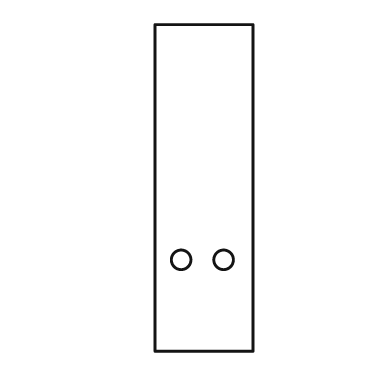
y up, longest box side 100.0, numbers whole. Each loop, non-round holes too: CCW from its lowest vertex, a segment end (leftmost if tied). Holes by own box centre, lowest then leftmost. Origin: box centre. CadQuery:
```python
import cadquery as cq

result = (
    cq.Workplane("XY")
    .moveTo(-15.0, -50.0)
    .lineTo(15.0, -50.0)
    .lineTo(15.0, 50.0)
    .lineTo(-15.0, 50.0)
    .close()
    .moveTo(-7.0, -22.0)
    .circle(3.0)
    .moveTo(6.0, -22.0)
    .circle(3.0)
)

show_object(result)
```